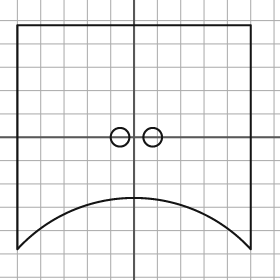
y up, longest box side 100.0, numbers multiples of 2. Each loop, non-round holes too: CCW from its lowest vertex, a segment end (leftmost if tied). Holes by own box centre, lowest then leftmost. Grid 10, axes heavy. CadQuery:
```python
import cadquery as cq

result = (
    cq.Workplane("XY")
    .moveTo(-50.0, -48.0)
    .threePointArc((0.0, -26.0), (50.0, -48.0))
    .lineTo(50.0, 48.0)
    .lineTo(-50.0, 48.0)
    .close()
    .moveTo(-6.0, 0.0)
    .circle(4.0)
    .moveTo(8.0, 0.0)
    .circle(4.0)
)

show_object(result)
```